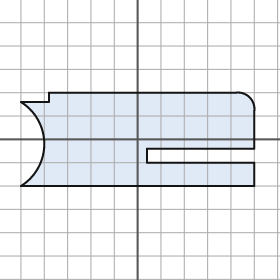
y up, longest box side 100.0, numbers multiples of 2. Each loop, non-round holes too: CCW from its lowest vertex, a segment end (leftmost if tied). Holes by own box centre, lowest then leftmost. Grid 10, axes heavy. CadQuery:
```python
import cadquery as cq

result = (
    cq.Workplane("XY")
    .moveTo(-50.0, -20.0)
    .lineTo(50.0, -20.0)
    .lineTo(50.0, -10.0)
    .lineTo(4.0, -10.0)
    .lineTo(4.0, -4.0)
    .lineTo(50.0, -4.0)
    .lineTo(50.0, 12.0)
    .threePointArc((48.0, 18.0), (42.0, 20.0))
    .lineTo(-38.0, 20.0)
    .lineTo(-38.0, 16.0)
    .lineTo(-50.0, 16.0)
    .threePointArc((-40.0, -2.0), (-50.0, -20.0))
    .close()
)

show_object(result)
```